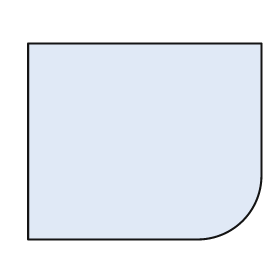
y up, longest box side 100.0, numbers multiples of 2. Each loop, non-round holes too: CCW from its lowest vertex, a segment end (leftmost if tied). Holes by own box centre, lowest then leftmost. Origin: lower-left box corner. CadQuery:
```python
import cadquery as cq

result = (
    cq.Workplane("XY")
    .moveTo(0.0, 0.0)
    .lineTo(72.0, 0.0)
    .threePointArc((92.0, 8.0), (100.0, 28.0))
    .lineTo(100.0, 84.0)
    .lineTo(0.0, 84.0)
    .close()
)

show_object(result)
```